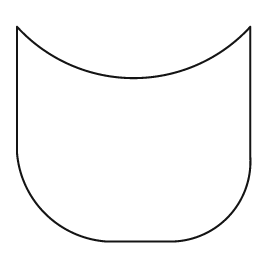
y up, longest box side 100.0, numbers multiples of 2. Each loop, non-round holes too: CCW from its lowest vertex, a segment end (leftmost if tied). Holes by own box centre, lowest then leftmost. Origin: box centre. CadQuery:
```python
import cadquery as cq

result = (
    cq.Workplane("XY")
    .moveTo(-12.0, -46.0)
    .lineTo(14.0, -46.0)
    .threePointArc((40.0, -36.0), (50.0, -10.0))
    .lineTo(50.0, 46.0)
    .threePointArc((0.0, 24.0), (-50.0, 46.0))
    .lineTo(-50.0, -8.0)
    .threePointArc((-38.0, -34.0), (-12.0, -46.0))
    .close()
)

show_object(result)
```